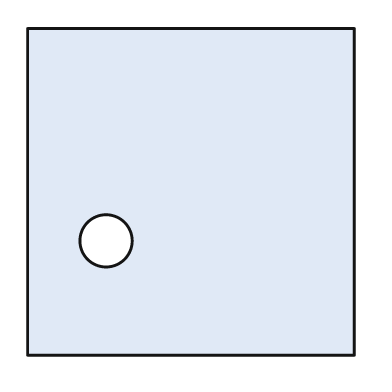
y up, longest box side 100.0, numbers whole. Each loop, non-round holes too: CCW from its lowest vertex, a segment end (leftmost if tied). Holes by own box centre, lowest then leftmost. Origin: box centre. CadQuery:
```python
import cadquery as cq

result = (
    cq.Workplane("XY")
    .moveTo(-50.0, -50.0)
    .lineTo(50.0, -50.0)
    .lineTo(50.0, 50.0)
    .lineTo(-50.0, 50.0)
    .close()
    .moveTo(-26.0, -15.0)
    .circle(8.0)
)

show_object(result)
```